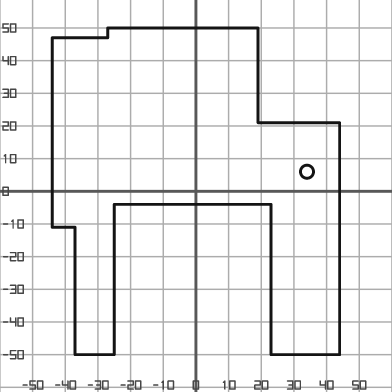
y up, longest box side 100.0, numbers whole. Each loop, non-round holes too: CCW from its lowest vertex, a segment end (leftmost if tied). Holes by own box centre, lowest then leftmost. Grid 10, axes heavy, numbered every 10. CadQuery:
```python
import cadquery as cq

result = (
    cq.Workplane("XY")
    .moveTo(-37.0, -50.0)
    .lineTo(-25.0, -50.0)
    .lineTo(-25.0, -4.0)
    .lineTo(23.0, -4.0)
    .lineTo(23.0, -50.0)
    .lineTo(44.0, -50.0)
    .lineTo(44.0, 21.0)
    .lineTo(19.0, 21.0)
    .lineTo(19.0, 50.0)
    .lineTo(-27.0, 50.0)
    .lineTo(-27.0, 47.0)
    .lineTo(-44.0, 47.0)
    .lineTo(-44.0, -11.0)
    .lineTo(-37.0, -11.0)
    .close()
    .moveTo(34.0, 6.0)
    .circle(2.0)
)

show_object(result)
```